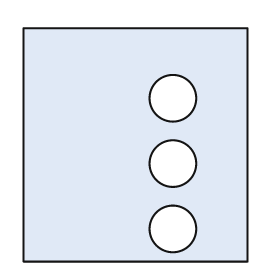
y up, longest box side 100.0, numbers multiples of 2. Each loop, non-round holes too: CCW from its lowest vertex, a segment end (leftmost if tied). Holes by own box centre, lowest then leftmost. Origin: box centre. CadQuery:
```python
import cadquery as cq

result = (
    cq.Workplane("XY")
    .moveTo(-48.0, -50.0)
    .lineTo(48.0, -50.0)
    .lineTo(48.0, 50.0)
    .lineTo(-48.0, 50.0)
    .close()
    .moveTo(16.0, -36.0)
    .circle(10.0)
    .moveTo(16.0, -8.0)
    .circle(10.0)
    .moveTo(16.0, 20.0)
    .circle(10.0)
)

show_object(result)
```